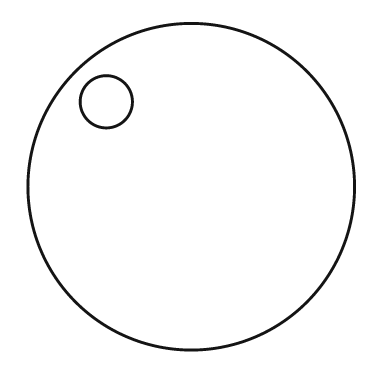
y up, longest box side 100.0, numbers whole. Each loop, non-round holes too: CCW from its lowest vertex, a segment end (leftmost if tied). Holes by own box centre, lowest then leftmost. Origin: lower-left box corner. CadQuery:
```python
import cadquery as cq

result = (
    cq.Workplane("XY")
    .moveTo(50.0, 50.0)
    .circle(50.0)
    .moveTo(24.0, 76.0)
    .circle(8.0)
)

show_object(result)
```